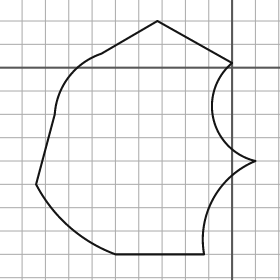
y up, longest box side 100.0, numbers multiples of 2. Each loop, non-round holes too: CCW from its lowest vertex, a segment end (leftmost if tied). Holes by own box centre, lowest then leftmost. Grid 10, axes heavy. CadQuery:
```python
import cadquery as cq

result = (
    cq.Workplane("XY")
    .moveTo(-50.0, -80.0)
    .lineTo(-12.0, -80.0)
    .threePointArc((-8.0, -56.0), (10.0, -40.0))
    .threePointArc((-8.0, -22.0), (0.0, 2.0))
    .lineTo(-32.0, 20.0)
    .lineTo(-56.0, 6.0)
    .threePointArc((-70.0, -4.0), (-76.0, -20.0))
    .lineTo(-84.0, -50.0)
    .threePointArc((-70.0, -68.0), (-50.0, -80.0))
    .close()
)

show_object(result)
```